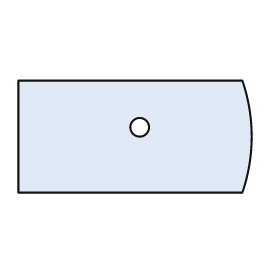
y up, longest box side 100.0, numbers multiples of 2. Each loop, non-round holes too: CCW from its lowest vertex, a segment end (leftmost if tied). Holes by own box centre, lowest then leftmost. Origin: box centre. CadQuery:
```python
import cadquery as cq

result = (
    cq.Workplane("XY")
    .moveTo(-50.0, -24.0)
    .lineTo(46.0, -24.0)
    .threePointArc((50.0, 0.0), (46.0, 24.0))
    .lineTo(-50.0, 24.0)
    .close()
    .moveTo(2.0, 4.0)
    .circle(4.0)
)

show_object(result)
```